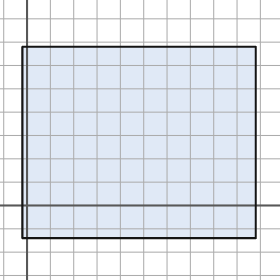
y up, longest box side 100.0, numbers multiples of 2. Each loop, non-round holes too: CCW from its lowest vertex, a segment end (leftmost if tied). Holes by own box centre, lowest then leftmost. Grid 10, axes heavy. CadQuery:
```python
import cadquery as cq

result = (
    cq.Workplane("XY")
    .moveTo(-2.0, -14.0)
    .lineTo(98.0, -14.0)
    .lineTo(98.0, 68.0)
    .lineTo(-2.0, 68.0)
    .close()
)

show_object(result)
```